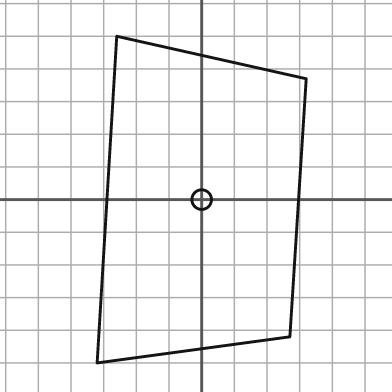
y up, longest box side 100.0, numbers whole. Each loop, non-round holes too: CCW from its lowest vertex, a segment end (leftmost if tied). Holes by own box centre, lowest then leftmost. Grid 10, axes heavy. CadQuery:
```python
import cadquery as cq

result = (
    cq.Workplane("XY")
    .moveTo(-32.0, -50.0)
    .lineTo(27.0, -42.0)
    .lineTo(32.0, 37.0)
    .lineTo(-26.0, 50.0)
    .close()
    .moveTo(0.0, 0.0)
    .circle(3.0)
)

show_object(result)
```